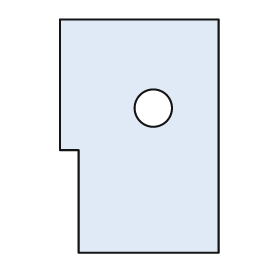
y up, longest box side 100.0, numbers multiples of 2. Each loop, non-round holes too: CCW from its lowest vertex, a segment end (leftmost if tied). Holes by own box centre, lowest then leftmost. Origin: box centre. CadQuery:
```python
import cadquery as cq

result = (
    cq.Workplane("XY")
    .moveTo(-26.0, -50.0)
    .lineTo(34.0, -50.0)
    .lineTo(34.0, 50.0)
    .lineTo(-34.0, 50.0)
    .lineTo(-34.0, -6.0)
    .lineTo(-26.0, -6.0)
    .close()
    .moveTo(6.0, 12.0)
    .circle(8.0)
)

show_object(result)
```